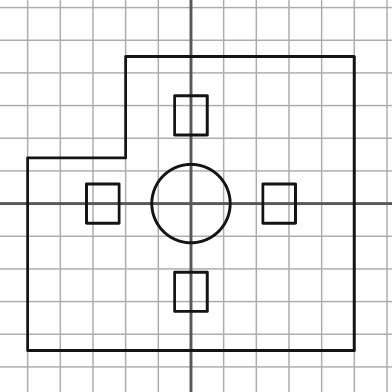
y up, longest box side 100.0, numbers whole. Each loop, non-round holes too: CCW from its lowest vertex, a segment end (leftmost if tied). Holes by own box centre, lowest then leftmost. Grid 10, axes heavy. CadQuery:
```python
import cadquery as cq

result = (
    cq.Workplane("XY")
    .moveTo(-50.0, -45.0)
    .lineTo(50.0, -45.0)
    .lineTo(50.0, 45.0)
    .lineTo(-20.0, 45.0)
    .lineTo(-20.0, 14.0)
    .lineTo(-50.0, 14.0)
    .close()
    .moveTo(-5.0, -33.0)
    .lineTo(5.0, -33.0)
    .lineTo(5.0, -21.0)
    .lineTo(-5.0, -21.0)
    .close()
    .moveTo(-32.0, -6.0)
    .lineTo(-22.0, -6.0)
    .lineTo(-22.0, 6.0)
    .lineTo(-32.0, 6.0)
    .close()
    .moveTo(0.0, 0.0)
    .circle(12.0)
    .moveTo(22.0, -6.0)
    .lineTo(32.0, -6.0)
    .lineTo(32.0, 6.0)
    .lineTo(22.0, 6.0)
    .close()
    .moveTo(-5.0, 21.0)
    .lineTo(5.0, 21.0)
    .lineTo(5.0, 33.0)
    .lineTo(-5.0, 33.0)
    .close()
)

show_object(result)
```